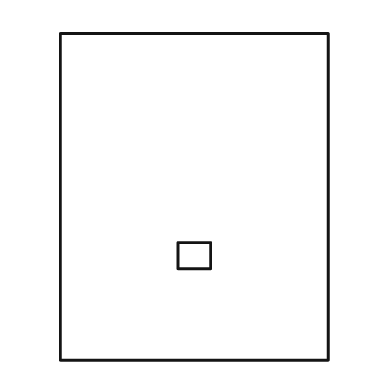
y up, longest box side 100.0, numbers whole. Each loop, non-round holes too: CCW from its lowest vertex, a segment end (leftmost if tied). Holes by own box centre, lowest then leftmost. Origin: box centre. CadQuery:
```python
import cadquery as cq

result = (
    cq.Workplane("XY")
    .moveTo(-41.0, -50.0)
    .lineTo(41.0, -50.0)
    .lineTo(41.0, 50.0)
    .lineTo(-41.0, 50.0)
    .close()
    .moveTo(-5.0, -22.0)
    .lineTo(5.0, -22.0)
    .lineTo(5.0, -14.0)
    .lineTo(-5.0, -14.0)
    .close()
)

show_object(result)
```